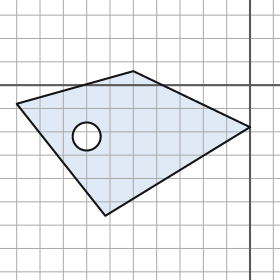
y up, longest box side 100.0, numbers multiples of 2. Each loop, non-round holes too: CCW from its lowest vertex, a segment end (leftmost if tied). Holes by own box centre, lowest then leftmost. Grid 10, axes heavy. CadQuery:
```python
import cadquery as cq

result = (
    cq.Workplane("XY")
    .moveTo(-62.0, -56.0)
    .lineTo(0.0, -18.0)
    .lineTo(-50.0, 6.0)
    .lineTo(-100.0, -8.0)
    .close()
    .moveTo(-70.0, -22.0)
    .circle(6.0)
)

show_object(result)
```